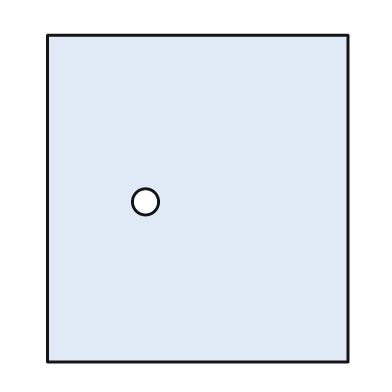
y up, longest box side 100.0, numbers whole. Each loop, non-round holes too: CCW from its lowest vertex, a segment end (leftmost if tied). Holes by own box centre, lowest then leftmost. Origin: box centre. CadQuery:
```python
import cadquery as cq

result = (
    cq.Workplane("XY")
    .moveTo(-46.0, -50.0)
    .lineTo(46.0, -50.0)
    .lineTo(46.0, 50.0)
    .lineTo(-46.0, 50.0)
    .close()
    .moveTo(-16.0, -1.0)
    .circle(4.0)
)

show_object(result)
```